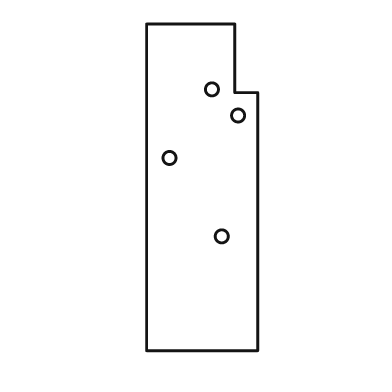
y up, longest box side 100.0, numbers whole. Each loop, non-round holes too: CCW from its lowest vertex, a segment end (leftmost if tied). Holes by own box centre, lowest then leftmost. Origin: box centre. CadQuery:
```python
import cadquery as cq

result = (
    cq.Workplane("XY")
    .moveTo(-17.0, -50.0)
    .lineTo(17.0, -50.0)
    .lineTo(17.0, 29.0)
    .lineTo(10.0, 29.0)
    .lineTo(10.0, 50.0)
    .lineTo(-17.0, 50.0)
    .close()
    .moveTo(6.0, -15.0)
    .circle(2.0)
    .moveTo(-10.0, 9.0)
    .circle(2.0)
    .moveTo(11.0, 22.0)
    .circle(2.0)
    .moveTo(3.0, 30.0)
    .circle(2.0)
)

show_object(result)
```